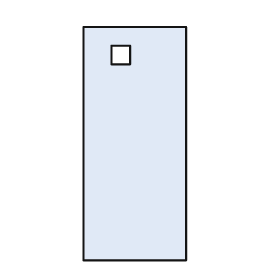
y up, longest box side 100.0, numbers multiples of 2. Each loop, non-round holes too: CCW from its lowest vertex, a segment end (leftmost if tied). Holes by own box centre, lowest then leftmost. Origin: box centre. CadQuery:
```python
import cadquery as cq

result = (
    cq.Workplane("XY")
    .moveTo(-22.0, -50.0)
    .lineTo(22.0, -50.0)
    .lineTo(22.0, 50.0)
    .lineTo(-22.0, 50.0)
    .close()
    .moveTo(-10.0, 34.0)
    .lineTo(-2.0, 34.0)
    .lineTo(-2.0, 42.0)
    .lineTo(-10.0, 42.0)
    .close()
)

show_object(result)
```